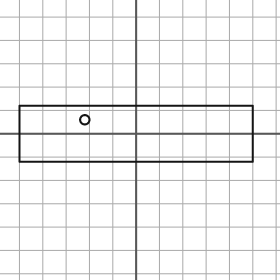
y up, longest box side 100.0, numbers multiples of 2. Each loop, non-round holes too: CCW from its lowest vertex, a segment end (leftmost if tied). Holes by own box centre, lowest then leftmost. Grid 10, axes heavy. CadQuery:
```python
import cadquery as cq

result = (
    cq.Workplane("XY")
    .moveTo(-50.0, -12.0)
    .lineTo(50.0, -12.0)
    .lineTo(50.0, 12.0)
    .lineTo(-50.0, 12.0)
    .close()
    .moveTo(-22.0, 6.0)
    .circle(2.0)
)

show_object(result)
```